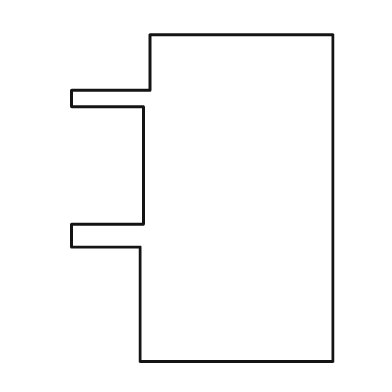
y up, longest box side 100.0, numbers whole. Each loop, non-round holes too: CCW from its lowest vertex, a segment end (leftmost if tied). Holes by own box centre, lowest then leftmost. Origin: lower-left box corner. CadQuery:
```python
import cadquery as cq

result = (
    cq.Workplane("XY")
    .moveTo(21.0, 0.0)
    .lineTo(80.0, 0.0)
    .lineTo(80.0, 100.0)
    .lineTo(24.0, 100.0)
    .lineTo(24.0, 83.0)
    .lineTo(0.0, 83.0)
    .lineTo(0.0, 78.0)
    .lineTo(22.0, 78.0)
    .lineTo(22.0, 42.0)
    .lineTo(0.0, 42.0)
    .lineTo(0.0, 35.0)
    .lineTo(21.0, 35.0)
    .close()
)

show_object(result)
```